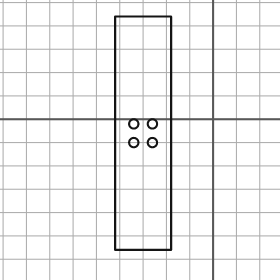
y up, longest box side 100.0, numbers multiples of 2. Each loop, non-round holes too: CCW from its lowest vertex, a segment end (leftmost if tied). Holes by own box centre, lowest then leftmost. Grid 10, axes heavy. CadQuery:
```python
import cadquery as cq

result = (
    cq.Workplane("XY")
    .moveTo(-42.0, -56.0)
    .lineTo(-18.0, -56.0)
    .lineTo(-18.0, 44.0)
    .lineTo(-42.0, 44.0)
    .close()
    .moveTo(-34.0, -10.0)
    .circle(2.0)
    .moveTo(-26.0, -10.0)
    .circle(2.0)
    .moveTo(-34.0, -2.0)
    .circle(2.0)
    .moveTo(-26.0, -2.0)
    .circle(2.0)
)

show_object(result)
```